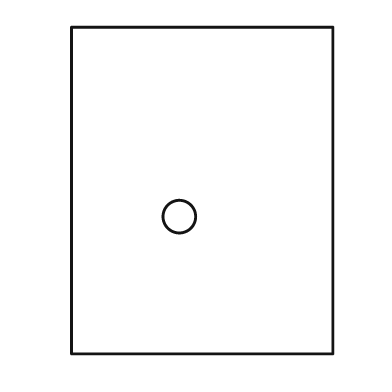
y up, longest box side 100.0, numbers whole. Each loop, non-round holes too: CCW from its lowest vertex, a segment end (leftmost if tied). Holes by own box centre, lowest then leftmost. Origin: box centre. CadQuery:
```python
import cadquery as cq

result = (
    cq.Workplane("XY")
    .moveTo(-40.0, -50.0)
    .lineTo(40.0, -50.0)
    .lineTo(40.0, 50.0)
    .lineTo(-40.0, 50.0)
    .close()
    .moveTo(-7.0, -8.0)
    .circle(5.0)
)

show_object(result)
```